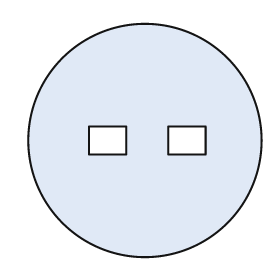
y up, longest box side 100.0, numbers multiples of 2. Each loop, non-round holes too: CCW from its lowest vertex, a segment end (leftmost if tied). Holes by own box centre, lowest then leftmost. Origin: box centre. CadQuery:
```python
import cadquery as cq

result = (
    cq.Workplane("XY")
    .moveTo(0.0, 0.0)
    .circle(50.0)
    .moveTo(-24.0, -6.0)
    .lineTo(-8.0, -6.0)
    .lineTo(-8.0, 6.0)
    .lineTo(-24.0, 6.0)
    .close()
    .moveTo(10.0, -6.0)
    .lineTo(26.0, -6.0)
    .lineTo(26.0, 6.0)
    .lineTo(10.0, 6.0)
    .close()
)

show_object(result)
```